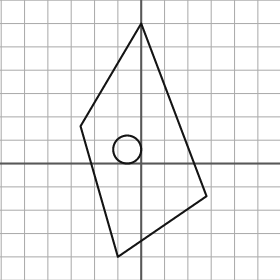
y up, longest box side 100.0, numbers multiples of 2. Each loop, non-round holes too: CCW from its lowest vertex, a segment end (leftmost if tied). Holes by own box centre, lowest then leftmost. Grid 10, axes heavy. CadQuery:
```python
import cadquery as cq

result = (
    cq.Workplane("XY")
    .moveTo(-10.0, -40.0)
    .lineTo(28.0, -14.0)
    .lineTo(0.0, 60.0)
    .lineTo(-26.0, 16.0)
    .close()
    .moveTo(-6.0, 6.0)
    .circle(6.0)
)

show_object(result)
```